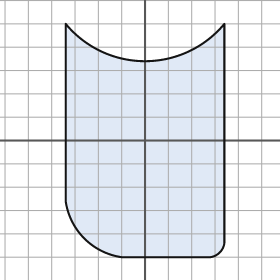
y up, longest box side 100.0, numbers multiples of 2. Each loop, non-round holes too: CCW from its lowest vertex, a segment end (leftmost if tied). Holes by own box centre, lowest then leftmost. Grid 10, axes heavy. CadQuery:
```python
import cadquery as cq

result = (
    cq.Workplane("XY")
    .moveTo(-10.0, -50.0)
    .lineTo(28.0, -50.0)
    .threePointArc((32.0, -48.0), (34.0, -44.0))
    .lineTo(34.0, 50.0)
    .threePointArc((0.0, 34.0), (-34.0, 50.0))
    .lineTo(-34.0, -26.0)
    .threePointArc((-26.0, -42.0), (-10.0, -50.0))
    .close()
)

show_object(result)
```